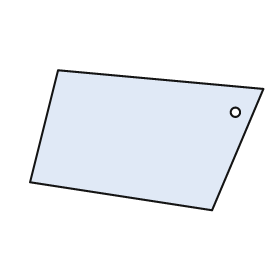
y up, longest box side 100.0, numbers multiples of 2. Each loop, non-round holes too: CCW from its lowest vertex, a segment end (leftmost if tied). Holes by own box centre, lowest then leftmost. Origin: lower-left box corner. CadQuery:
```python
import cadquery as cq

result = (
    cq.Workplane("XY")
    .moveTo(78.0, 0.0)
    .lineTo(100.0, 52.0)
    .lineTo(12.0, 60.0)
    .lineTo(0.0, 12.0)
    .close()
    .moveTo(88.0, 42.0)
    .circle(2.0)
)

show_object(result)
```